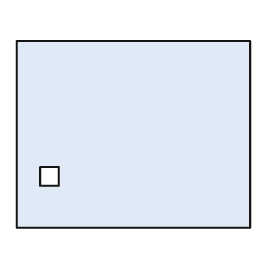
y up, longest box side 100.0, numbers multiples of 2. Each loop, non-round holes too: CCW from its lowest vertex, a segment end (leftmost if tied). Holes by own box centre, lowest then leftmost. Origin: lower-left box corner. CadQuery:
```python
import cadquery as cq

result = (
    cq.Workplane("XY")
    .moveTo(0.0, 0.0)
    .lineTo(100.0, 0.0)
    .lineTo(100.0, 80.0)
    .lineTo(0.0, 80.0)
    .close()
    .moveTo(10.0, 18.0)
    .lineTo(18.0, 18.0)
    .lineTo(18.0, 26.0)
    .lineTo(10.0, 26.0)
    .close()
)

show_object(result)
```